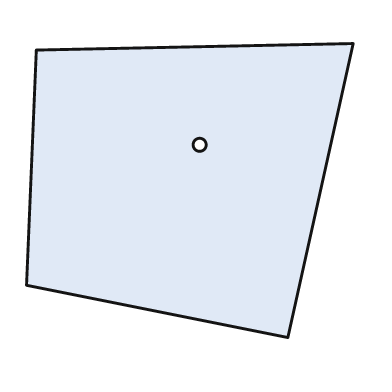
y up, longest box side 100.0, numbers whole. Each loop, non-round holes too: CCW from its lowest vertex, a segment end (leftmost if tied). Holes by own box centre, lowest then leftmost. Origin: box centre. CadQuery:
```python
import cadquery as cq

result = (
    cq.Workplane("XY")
    .moveTo(30.0, -45.0)
    .lineTo(50.0, 45.0)
    .lineTo(-47.0, 43.0)
    .lineTo(-50.0, -29.0)
    .close()
    .moveTo(3.0, 14.0)
    .circle(2.0)
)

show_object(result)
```